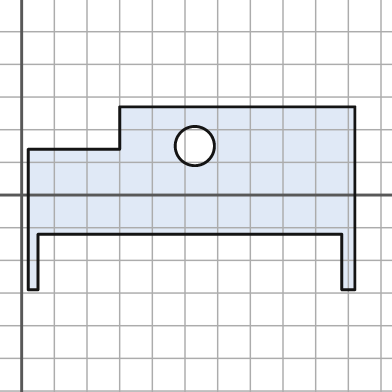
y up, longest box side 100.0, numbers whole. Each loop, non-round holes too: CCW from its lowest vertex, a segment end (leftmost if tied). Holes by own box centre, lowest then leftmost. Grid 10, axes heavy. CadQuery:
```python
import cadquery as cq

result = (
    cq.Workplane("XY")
    .moveTo(2.0, -29.0)
    .lineTo(5.0, -29.0)
    .lineTo(5.0, -12.0)
    .lineTo(98.0, -12.0)
    .lineTo(98.0, -29.0)
    .lineTo(102.0, -29.0)
    .lineTo(102.0, 27.0)
    .lineTo(30.0, 27.0)
    .lineTo(30.0, 14.0)
    .lineTo(2.0, 14.0)
    .close()
    .moveTo(53.0, 15.0)
    .circle(6.0)
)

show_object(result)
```